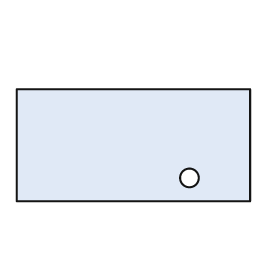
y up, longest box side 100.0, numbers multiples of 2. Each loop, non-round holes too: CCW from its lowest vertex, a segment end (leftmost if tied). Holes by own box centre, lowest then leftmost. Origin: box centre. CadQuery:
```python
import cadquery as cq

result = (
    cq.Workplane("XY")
    .moveTo(-50.0, -24.0)
    .lineTo(50.0, -24.0)
    .lineTo(50.0, 24.0)
    .lineTo(-50.0, 24.0)
    .close()
    .moveTo(24.0, -14.0)
    .circle(4.0)
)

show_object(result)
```